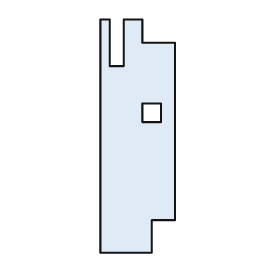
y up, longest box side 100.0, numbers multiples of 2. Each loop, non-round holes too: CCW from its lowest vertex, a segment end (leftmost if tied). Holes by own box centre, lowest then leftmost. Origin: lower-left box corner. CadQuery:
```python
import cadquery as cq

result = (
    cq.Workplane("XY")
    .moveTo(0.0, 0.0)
    .lineTo(22.0, 0.0)
    .lineTo(22.0, 14.0)
    .lineTo(32.0, 14.0)
    .lineTo(32.0, 90.0)
    .lineTo(18.0, 90.0)
    .lineTo(18.0, 100.0)
    .lineTo(10.0, 100.0)
    .lineTo(10.0, 80.0)
    .lineTo(4.0, 80.0)
    .lineTo(4.0, 100.0)
    .lineTo(0.0, 100.0)
    .close()
    .moveTo(18.0, 56.0)
    .lineTo(26.0, 56.0)
    .lineTo(26.0, 64.0)
    .lineTo(18.0, 64.0)
    .close()
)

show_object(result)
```